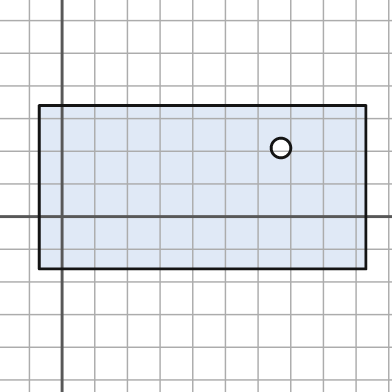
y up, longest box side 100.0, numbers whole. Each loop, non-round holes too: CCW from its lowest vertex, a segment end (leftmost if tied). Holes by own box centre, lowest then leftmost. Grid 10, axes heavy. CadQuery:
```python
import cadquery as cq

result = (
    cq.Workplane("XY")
    .moveTo(-7.0, -16.0)
    .lineTo(93.0, -16.0)
    .lineTo(93.0, 34.0)
    .lineTo(-7.0, 34.0)
    .close()
    .moveTo(67.0, 21.0)
    .circle(3.0)
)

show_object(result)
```